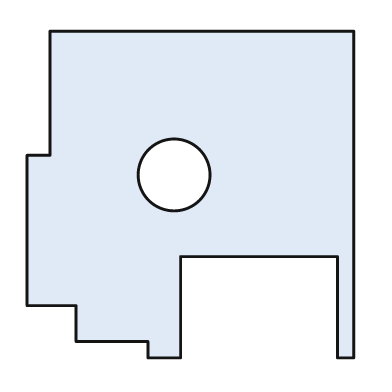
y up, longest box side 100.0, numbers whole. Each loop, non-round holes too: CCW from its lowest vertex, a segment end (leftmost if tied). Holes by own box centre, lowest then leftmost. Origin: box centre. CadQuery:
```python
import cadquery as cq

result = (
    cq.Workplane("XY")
    .moveTo(-13.0, -50.0)
    .lineTo(-3.0, -50.0)
    .lineTo(-3.0, -19.0)
    .lineTo(45.0, -19.0)
    .lineTo(45.0, -50.0)
    .lineTo(50.0, -50.0)
    .lineTo(50.0, 50.0)
    .lineTo(-43.0, 50.0)
    .lineTo(-43.0, 12.0)
    .lineTo(-50.0, 12.0)
    .lineTo(-50.0, -34.0)
    .lineTo(-35.0, -34.0)
    .lineTo(-35.0, -45.0)
    .lineTo(-13.0, -45.0)
    .close()
    .moveTo(-5.0, 6.0)
    .circle(11.0)
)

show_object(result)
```